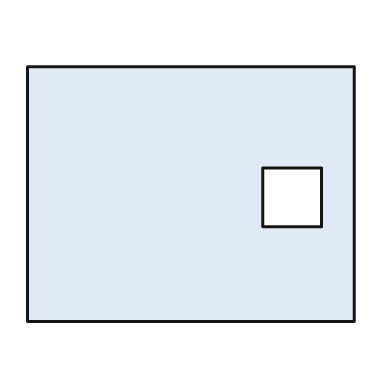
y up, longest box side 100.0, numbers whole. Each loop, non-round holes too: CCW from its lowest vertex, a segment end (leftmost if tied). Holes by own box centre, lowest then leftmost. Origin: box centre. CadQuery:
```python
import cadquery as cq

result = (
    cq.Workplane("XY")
    .moveTo(-50.0, -39.0)
    .lineTo(50.0, -39.0)
    .lineTo(50.0, 39.0)
    .lineTo(-50.0, 39.0)
    .close()
    .moveTo(22.0, -10.0)
    .lineTo(40.0, -10.0)
    .lineTo(40.0, 8.0)
    .lineTo(22.0, 8.0)
    .close()
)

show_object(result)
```